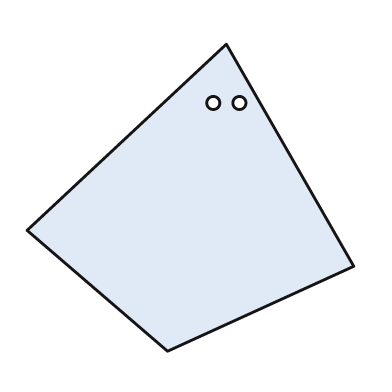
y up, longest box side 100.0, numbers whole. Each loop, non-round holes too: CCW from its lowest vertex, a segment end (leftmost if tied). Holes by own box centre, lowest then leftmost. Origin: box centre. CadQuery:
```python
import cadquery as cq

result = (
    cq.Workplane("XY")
    .moveTo(-7.0, -47.0)
    .lineTo(50.0, -21.0)
    .lineTo(11.0, 47.0)
    .lineTo(-50.0, -10.0)
    .close()
    .moveTo(7.0, 29.0)
    .circle(2.0)
    .moveTo(15.0, 29.0)
    .circle(2.0)
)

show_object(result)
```